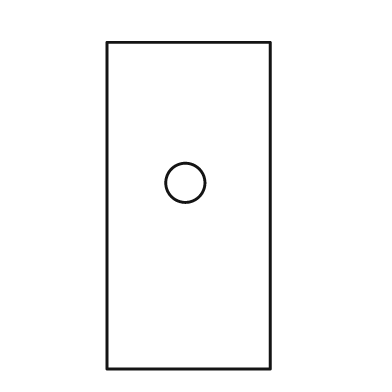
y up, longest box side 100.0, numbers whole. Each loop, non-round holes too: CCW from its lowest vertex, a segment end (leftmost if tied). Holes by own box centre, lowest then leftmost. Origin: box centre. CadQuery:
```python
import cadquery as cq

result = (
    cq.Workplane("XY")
    .moveTo(-25.0, -50.0)
    .lineTo(25.0, -50.0)
    .lineTo(25.0, 50.0)
    .lineTo(-25.0, 50.0)
    .close()
    .moveTo(-1.0, 7.0)
    .circle(6.0)
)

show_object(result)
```